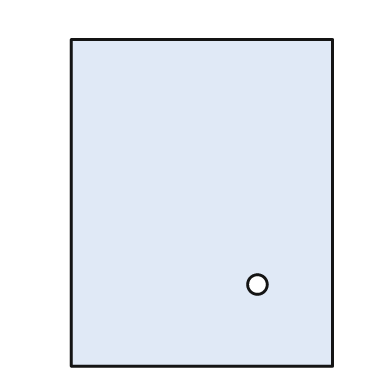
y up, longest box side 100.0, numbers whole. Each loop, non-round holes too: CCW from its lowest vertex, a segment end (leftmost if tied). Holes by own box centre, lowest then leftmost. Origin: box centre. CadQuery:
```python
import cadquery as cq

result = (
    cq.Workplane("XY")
    .moveTo(-40.0, -50.0)
    .lineTo(40.0, -50.0)
    .lineTo(40.0, 50.0)
    .lineTo(-40.0, 50.0)
    .close()
    .moveTo(17.0, -25.0)
    .circle(3.0)
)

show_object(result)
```